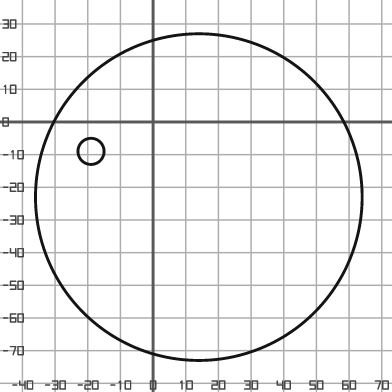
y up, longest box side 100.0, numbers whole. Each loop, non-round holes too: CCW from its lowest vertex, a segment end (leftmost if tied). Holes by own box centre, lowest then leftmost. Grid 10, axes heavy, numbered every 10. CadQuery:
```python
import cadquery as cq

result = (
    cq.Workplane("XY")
    .moveTo(14.0, -23.0)
    .circle(50.0)
    .moveTo(-19.0, -9.0)
    .circle(4.0)
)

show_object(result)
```